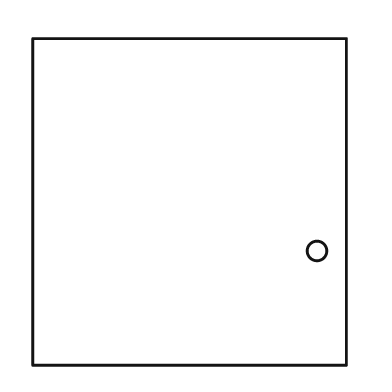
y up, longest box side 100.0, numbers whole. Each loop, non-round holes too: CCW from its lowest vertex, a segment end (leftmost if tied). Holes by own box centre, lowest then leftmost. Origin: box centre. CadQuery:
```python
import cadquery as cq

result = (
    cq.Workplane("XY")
    .moveTo(-48.0, -50.0)
    .lineTo(48.0, -50.0)
    .lineTo(48.0, 50.0)
    .lineTo(-48.0, 50.0)
    .close()
    .moveTo(39.0, -15.0)
    .circle(3.0)
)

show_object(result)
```